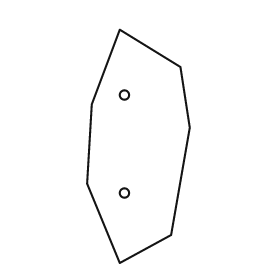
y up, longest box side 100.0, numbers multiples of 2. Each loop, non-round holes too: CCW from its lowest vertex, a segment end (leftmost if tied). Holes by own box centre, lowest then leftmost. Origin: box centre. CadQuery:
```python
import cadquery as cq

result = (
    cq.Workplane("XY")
    .moveTo(-8.0, -50.0)
    .lineTo(14.0, -38.0)
    .lineTo(22.0, 8.0)
    .lineTo(18.0, 34.0)
    .lineTo(-8.0, 50.0)
    .lineTo(-20.0, 18.0)
    .lineTo(-22.0, -16.0)
    .close()
    .moveTo(-6.0, -20.0)
    .circle(2.0)
    .moveTo(-6.0, 22.0)
    .circle(2.0)
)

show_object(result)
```